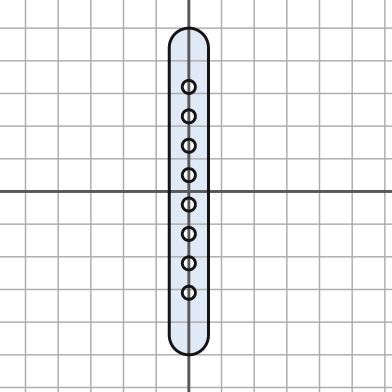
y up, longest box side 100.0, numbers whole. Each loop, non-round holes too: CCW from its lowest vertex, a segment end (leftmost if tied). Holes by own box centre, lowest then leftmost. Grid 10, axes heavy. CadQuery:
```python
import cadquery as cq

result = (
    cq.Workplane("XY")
    .moveTo(-6.0, -44.0)
    .threePointArc((0.0, -50.0), (6.0, -44.0))
    .lineTo(6.0, 44.0)
    .threePointArc((0.0, 50.0), (-6.0, 44.0))
    .close()
    .moveTo(0.0, -31.0)
    .circle(2.0)
    .moveTo(0.0, -22.0)
    .circle(2.0)
    .moveTo(0.0, -13.0)
    .circle(2.0)
    .moveTo(0.0, -4.0)
    .circle(2.0)
    .moveTo(0.0, 5.0)
    .circle(2.0)
    .moveTo(0.0, 14.0)
    .circle(2.0)
    .moveTo(0.0, 23.0)
    .circle(2.0)
    .moveTo(0.0, 32.0)
    .circle(2.0)
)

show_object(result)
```